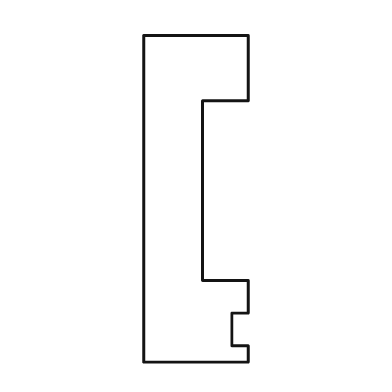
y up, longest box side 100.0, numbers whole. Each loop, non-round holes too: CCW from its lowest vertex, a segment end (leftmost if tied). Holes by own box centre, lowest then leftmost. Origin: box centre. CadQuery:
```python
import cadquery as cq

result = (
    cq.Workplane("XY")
    .moveTo(-16.0, -50.0)
    .lineTo(16.0, -50.0)
    .lineTo(16.0, -45.0)
    .lineTo(11.0, -45.0)
    .lineTo(11.0, -35.0)
    .lineTo(16.0, -35.0)
    .lineTo(16.0, -25.0)
    .lineTo(2.0, -25.0)
    .lineTo(2.0, 30.0)
    .lineTo(16.0, 30.0)
    .lineTo(16.0, 50.0)
    .lineTo(-16.0, 50.0)
    .close()
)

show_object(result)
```